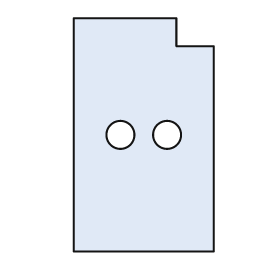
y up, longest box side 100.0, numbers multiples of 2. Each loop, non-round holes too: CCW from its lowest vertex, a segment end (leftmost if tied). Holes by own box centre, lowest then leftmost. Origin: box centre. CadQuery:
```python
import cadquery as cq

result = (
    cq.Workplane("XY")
    .moveTo(-30.0, -50.0)
    .lineTo(30.0, -50.0)
    .lineTo(30.0, 38.0)
    .lineTo(14.0, 38.0)
    .lineTo(14.0, 50.0)
    .lineTo(-30.0, 50.0)
    .close()
    .moveTo(-10.0, 0.0)
    .circle(6.0)
    .moveTo(10.0, 0.0)
    .circle(6.0)
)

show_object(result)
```